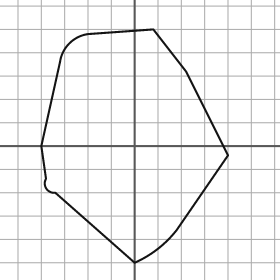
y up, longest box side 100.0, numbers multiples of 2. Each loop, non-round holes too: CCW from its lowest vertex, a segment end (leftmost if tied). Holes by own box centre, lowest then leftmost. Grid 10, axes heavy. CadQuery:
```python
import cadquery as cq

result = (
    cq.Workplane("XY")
    .moveTo(0.0, -50.0)
    .threePointArc((10.0, -44.0), (18.0, -36.0))
    .lineTo(40.0, -4.0)
    .lineTo(22.0, 32.0)
    .lineTo(8.0, 50.0)
    .lineTo(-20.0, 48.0)
    .threePointArc((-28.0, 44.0), (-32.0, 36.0))
    .lineTo(-40.0, 0.0)
    .lineTo(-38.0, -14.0)
    .threePointArc((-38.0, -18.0), (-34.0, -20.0))
    .close()
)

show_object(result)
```